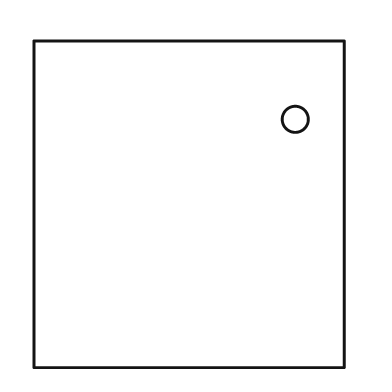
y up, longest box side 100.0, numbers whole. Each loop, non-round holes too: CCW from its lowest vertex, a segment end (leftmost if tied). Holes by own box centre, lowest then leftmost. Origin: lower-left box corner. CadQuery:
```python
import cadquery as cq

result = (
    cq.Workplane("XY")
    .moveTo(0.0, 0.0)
    .lineTo(95.0, 0.0)
    .lineTo(95.0, 100.0)
    .lineTo(0.0, 100.0)
    .close()
    .moveTo(80.0, 76.0)
    .circle(4.0)
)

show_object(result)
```